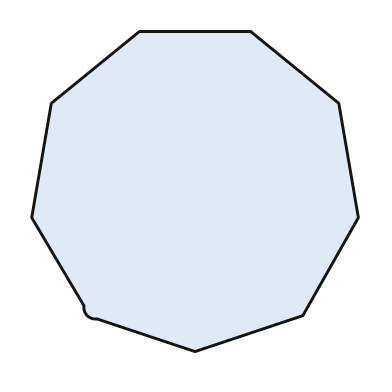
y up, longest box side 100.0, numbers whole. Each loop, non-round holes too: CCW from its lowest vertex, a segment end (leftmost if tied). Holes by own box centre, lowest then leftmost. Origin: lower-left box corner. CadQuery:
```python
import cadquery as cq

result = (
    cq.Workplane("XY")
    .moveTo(50.0, 0.0)
    .lineTo(83.0, 11.0)
    .lineTo(100.0, 41.0)
    .lineTo(94.0, 76.0)
    .lineTo(67.0, 98.0)
    .lineTo(33.0, 98.0)
    .lineTo(6.0, 76.0)
    .lineTo(0.0, 41.0)
    .lineTo(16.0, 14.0)
    .threePointArc((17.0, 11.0), (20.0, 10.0))
    .close()
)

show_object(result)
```